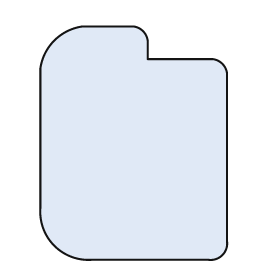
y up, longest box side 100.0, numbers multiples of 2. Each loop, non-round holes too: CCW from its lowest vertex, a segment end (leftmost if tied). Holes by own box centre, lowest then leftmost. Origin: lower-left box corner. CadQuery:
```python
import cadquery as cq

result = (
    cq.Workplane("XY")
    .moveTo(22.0, 0.0)
    .lineTo(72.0, 0.0)
    .threePointArc((78.0, 2.0), (80.0, 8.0))
    .lineTo(80.0, 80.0)
    .threePointArc((78.0, 84.0), (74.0, 86.0))
    .lineTo(46.0, 86.0)
    .lineTo(46.0, 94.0)
    .threePointArc((44.0, 98.0), (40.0, 100.0))
    .lineTo(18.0, 100.0)
    .threePointArc((6.0, 94.0), (0.0, 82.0))
    .lineTo(0.0, 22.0)
    .threePointArc((6.0, 6.0), (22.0, 0.0))
    .close()
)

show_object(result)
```